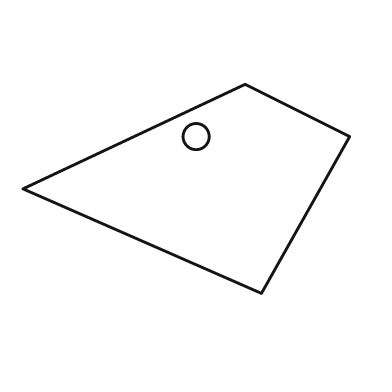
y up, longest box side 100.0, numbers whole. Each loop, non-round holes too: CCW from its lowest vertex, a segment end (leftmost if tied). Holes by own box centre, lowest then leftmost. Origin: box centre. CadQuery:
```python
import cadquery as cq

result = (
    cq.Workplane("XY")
    .moveTo(23.0, -32.0)
    .lineTo(50.0, 16.0)
    .lineTo(18.0, 32.0)
    .lineTo(-50.0, 0.0)
    .close()
    .moveTo(3.0, 16.0)
    .circle(4.0)
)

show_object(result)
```